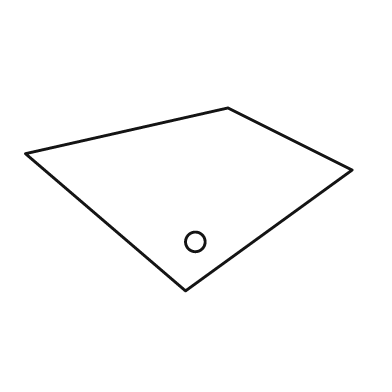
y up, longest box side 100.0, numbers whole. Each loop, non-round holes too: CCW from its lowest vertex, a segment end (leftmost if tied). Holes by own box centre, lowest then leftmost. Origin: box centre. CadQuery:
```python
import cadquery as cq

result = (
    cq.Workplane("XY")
    .moveTo(-1.0, -28.0)
    .lineTo(50.0, 9.0)
    .lineTo(12.0, 28.0)
    .lineTo(-50.0, 14.0)
    .close()
    .moveTo(2.0, -13.0)
    .circle(3.0)
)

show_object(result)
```